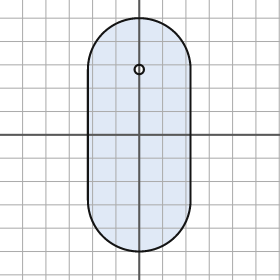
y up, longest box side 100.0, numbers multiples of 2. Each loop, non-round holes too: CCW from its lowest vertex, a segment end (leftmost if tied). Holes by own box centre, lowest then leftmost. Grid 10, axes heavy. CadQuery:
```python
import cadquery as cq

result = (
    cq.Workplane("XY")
    .moveTo(-22.0, -28.0)
    .threePointArc((0.0, -50.0), (22.0, -28.0))
    .lineTo(22.0, 28.0)
    .threePointArc((0.0, 50.0), (-22.0, 28.0))
    .close()
    .moveTo(0.0, 28.0)
    .circle(2.0)
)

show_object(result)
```